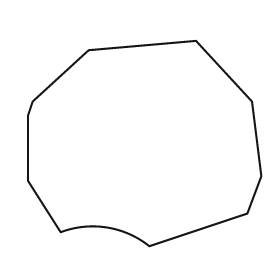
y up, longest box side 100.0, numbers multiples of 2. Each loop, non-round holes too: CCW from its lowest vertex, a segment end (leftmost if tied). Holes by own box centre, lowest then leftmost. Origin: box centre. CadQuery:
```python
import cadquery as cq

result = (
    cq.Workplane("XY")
    .moveTo(2.0, -44.0)
    .lineTo(44.0, -30.0)
    .lineTo(50.0, -14.0)
    .lineTo(46.0, 18.0)
    .lineTo(22.0, 44.0)
    .lineTo(-24.0, 40.0)
    .lineTo(-48.0, 18.0)
    .lineTo(-50.0, 12.0)
    .lineTo(-50.0, -16.0)
    .lineTo(-36.0, -38.0)
    .threePointArc((-16.0, -36.0), (2.0, -44.0))
    .close()
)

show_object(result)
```